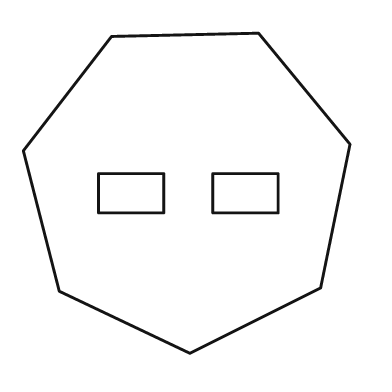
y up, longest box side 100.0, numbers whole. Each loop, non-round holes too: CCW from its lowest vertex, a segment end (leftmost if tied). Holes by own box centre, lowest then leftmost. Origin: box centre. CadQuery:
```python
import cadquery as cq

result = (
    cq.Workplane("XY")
    .moveTo(1.0, -49.0)
    .lineTo(41.0, -29.0)
    .lineTo(50.0, 15.0)
    .lineTo(22.0, 49.0)
    .lineTo(-23.0, 48.0)
    .lineTo(-50.0, 13.0)
    .lineTo(-39.0, -30.0)
    .close()
    .moveTo(-27.0, -6.0)
    .lineTo(-7.0, -6.0)
    .lineTo(-7.0, 6.0)
    .lineTo(-27.0, 6.0)
    .close()
    .moveTo(8.0, -6.0)
    .lineTo(28.0, -6.0)
    .lineTo(28.0, 6.0)
    .lineTo(8.0, 6.0)
    .close()
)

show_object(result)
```